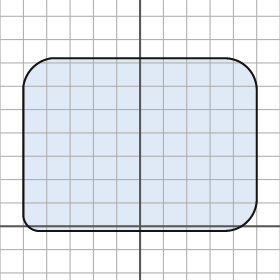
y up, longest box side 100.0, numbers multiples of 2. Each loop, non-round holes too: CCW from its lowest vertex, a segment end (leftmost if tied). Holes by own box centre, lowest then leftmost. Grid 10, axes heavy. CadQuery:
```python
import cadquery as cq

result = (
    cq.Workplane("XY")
    .moveTo(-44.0, -2.0)
    .lineTo(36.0, -2.0)
    .threePointArc((46.0, 2.0), (50.0, 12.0))
    .lineTo(50.0, 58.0)
    .threePointArc((46.0, 68.0), (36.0, 72.0))
    .lineTo(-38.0, 72.0)
    .threePointArc((-46.0, 68.0), (-50.0, 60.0))
    .lineTo(-50.0, 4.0)
    .threePointArc((-48.0, 0.0), (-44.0, -2.0))
    .close()
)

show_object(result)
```